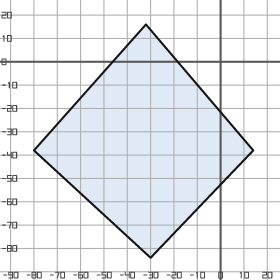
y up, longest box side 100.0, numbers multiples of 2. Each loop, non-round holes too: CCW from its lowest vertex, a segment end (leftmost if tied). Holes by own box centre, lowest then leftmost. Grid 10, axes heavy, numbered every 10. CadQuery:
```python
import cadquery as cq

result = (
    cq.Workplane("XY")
    .moveTo(-30.0, -84.0)
    .lineTo(14.0, -38.0)
    .lineTo(-32.0, 16.0)
    .lineTo(-80.0, -38.0)
    .close()
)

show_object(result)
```